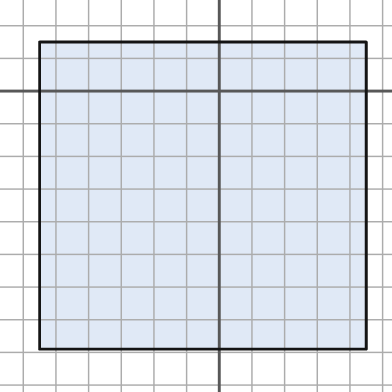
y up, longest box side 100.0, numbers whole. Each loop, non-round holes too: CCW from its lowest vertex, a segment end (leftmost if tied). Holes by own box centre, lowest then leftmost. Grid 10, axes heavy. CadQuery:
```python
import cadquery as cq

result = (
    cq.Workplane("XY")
    .moveTo(-55.0, -79.0)
    .lineTo(45.0, -79.0)
    .lineTo(45.0, 15.0)
    .lineTo(-55.0, 15.0)
    .close()
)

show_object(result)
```